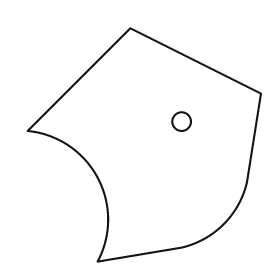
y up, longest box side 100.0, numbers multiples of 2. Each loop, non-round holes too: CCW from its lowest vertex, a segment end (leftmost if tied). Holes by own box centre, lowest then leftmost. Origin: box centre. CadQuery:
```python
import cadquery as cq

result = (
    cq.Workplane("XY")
    .moveTo(-20.0, -50.0)
    .lineTo(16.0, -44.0)
    .threePointArc((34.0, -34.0), (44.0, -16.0))
    .lineTo(50.0, 22.0)
    .lineTo(-6.0, 50.0)
    .lineTo(-50.0, 6.0)
    .threePointArc((-20.0, -14.0), (-20.0, -50.0))
    .close()
    .moveTo(16.0, 10.0)
    .circle(4.0)
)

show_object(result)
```